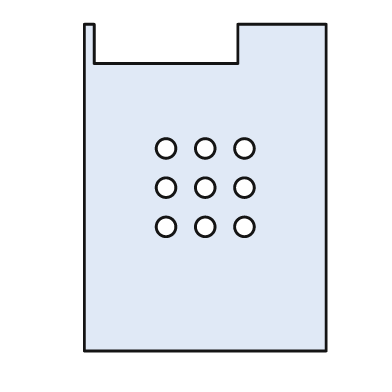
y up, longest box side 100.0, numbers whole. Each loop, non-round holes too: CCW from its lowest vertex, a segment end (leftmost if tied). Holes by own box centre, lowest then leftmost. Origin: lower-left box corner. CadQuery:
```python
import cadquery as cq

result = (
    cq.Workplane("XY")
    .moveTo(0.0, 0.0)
    .lineTo(74.0, 0.0)
    .lineTo(74.0, 100.0)
    .lineTo(47.0, 100.0)
    .lineTo(47.0, 88.0)
    .lineTo(3.0, 88.0)
    .lineTo(3.0, 100.0)
    .lineTo(0.0, 100.0)
    .close()
    .moveTo(25.0, 38.0)
    .circle(3.0)
    .moveTo(37.0, 38.0)
    .circle(3.0)
    .moveTo(49.0, 38.0)
    .circle(3.0)
    .moveTo(25.0, 50.0)
    .circle(3.0)
    .moveTo(37.0, 50.0)
    .circle(3.0)
    .moveTo(49.0, 50.0)
    .circle(3.0)
    .moveTo(25.0, 62.0)
    .circle(3.0)
    .moveTo(37.0, 62.0)
    .circle(3.0)
    .moveTo(49.0, 62.0)
    .circle(3.0)
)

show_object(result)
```